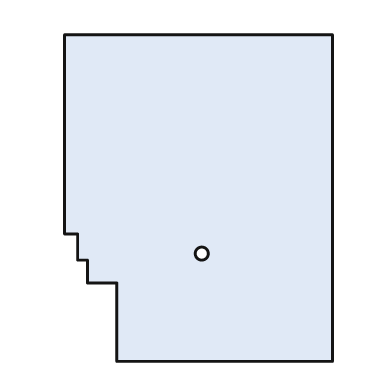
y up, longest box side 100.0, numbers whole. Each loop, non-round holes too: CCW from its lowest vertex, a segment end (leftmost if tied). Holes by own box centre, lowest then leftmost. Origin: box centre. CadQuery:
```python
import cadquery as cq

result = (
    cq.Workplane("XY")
    .moveTo(-25.0, -50.0)
    .lineTo(41.0, -50.0)
    .lineTo(41.0, 50.0)
    .lineTo(-41.0, 50.0)
    .lineTo(-41.0, -11.0)
    .lineTo(-37.0, -11.0)
    .lineTo(-37.0, -19.0)
    .lineTo(-34.0, -19.0)
    .lineTo(-34.0, -26.0)
    .lineTo(-25.0, -26.0)
    .close()
    .moveTo(1.0, -17.0)
    .circle(2.0)
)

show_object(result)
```